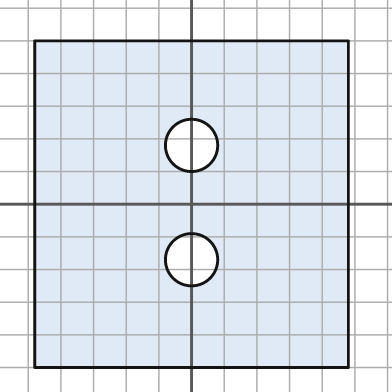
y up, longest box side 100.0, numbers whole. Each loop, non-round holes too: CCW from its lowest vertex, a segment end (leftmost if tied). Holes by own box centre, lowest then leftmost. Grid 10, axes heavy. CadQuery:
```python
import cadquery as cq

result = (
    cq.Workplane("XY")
    .moveTo(-48.0, -50.0)
    .lineTo(48.0, -50.0)
    .lineTo(48.0, 50.0)
    .lineTo(-48.0, 50.0)
    .close()
    .moveTo(0.0, -17.0)
    .circle(8.0)
    .moveTo(0.0, 18.0)
    .circle(8.0)
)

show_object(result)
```